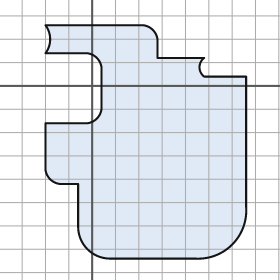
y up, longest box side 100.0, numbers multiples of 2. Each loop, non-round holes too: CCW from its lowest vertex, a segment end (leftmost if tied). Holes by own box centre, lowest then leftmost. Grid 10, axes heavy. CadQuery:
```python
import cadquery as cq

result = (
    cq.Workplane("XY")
    .moveTo(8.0, -74.0)
    .lineTo(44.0, -74.0)
    .threePointArc((60.0, -68.0), (66.0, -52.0))
    .lineTo(66.0, 4.0)
    .lineTo(48.0, 4.0)
    .threePointArc((46.0, 8.0), (48.0, 12.0))
    .lineTo(28.0, 12.0)
    .lineTo(28.0, 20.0)
    .threePointArc((26.0, 24.0), (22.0, 26.0))
    .lineTo(-20.0, 26.0)
    .threePointArc((-18.0, 20.0), (-20.0, 14.0))
    .lineTo(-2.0, 14.0)
    .threePointArc((2.0, 12.0), (4.0, 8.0))
    .lineTo(4.0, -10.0)
    .threePointArc((2.0, -14.0), (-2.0, -16.0))
    .lineTo(-20.0, -16.0)
    .lineTo(-20.0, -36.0)
    .threePointArc((-18.0, -40.0), (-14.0, -42.0))
    .lineTo(-6.0, -42.0)
    .lineTo(-6.0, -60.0)
    .threePointArc((-2.0, -70.0), (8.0, -74.0))
    .close()
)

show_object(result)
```